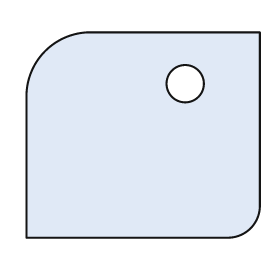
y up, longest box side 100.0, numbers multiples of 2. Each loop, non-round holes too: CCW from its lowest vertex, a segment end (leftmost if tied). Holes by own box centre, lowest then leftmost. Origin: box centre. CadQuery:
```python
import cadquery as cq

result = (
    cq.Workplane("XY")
    .moveTo(-50.0, -44.0)
    .lineTo(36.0, -44.0)
    .threePointArc((46.0, -40.0), (50.0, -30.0))
    .lineTo(50.0, 44.0)
    .lineTo(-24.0, 44.0)
    .threePointArc((-42.0, 36.0), (-50.0, 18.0))
    .close()
    .moveTo(18.0, 22.0)
    .circle(8.0)
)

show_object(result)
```